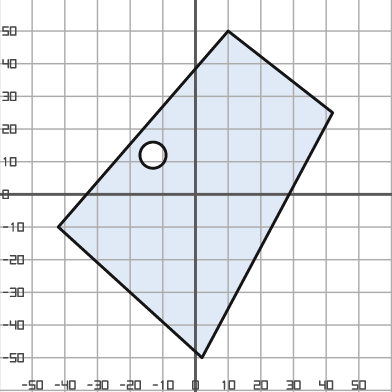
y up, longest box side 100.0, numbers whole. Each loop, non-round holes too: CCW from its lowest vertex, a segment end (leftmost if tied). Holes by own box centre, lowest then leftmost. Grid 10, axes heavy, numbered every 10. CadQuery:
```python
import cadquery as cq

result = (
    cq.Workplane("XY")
    .moveTo(2.0, -50.0)
    .lineTo(42.0, 25.0)
    .lineTo(10.0, 50.0)
    .lineTo(-42.0, -10.0)
    .close()
    .moveTo(-13.0, 12.0)
    .circle(4.0)
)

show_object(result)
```